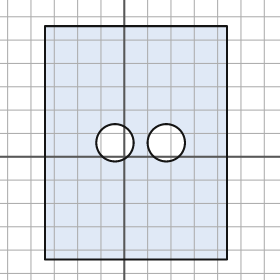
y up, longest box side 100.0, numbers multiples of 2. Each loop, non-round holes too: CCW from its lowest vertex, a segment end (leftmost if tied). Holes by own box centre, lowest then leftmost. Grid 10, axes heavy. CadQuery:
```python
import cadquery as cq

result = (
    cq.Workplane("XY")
    .moveTo(-34.0, -44.0)
    .lineTo(44.0, -44.0)
    .lineTo(44.0, 56.0)
    .lineTo(-34.0, 56.0)
    .close()
    .moveTo(-4.0, 6.0)
    .circle(8.0)
    .moveTo(18.0, 6.0)
    .circle(8.0)
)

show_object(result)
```